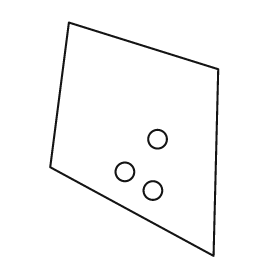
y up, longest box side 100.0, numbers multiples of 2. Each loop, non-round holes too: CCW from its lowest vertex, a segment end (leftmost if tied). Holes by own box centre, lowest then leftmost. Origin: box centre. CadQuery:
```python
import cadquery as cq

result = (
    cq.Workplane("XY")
    .moveTo(34.0, -50.0)
    .lineTo(36.0, 30.0)
    .lineTo(-28.0, 50.0)
    .lineTo(-36.0, -12.0)
    .close()
    .moveTo(8.0, -22.0)
    .circle(4.0)
    .moveTo(-4.0, -14.0)
    .circle(4.0)
    .moveTo(10.0, 0.0)
    .circle(4.0)
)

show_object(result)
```